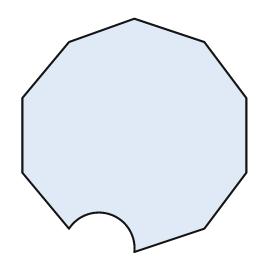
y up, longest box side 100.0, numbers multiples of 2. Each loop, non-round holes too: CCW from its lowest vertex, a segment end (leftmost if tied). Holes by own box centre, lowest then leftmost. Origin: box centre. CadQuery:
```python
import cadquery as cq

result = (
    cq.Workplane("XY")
    .moveTo(0.0, -50.0)
    .lineTo(30.0, -40.0)
    .lineTo(48.0, -16.0)
    .lineTo(48.0, 16.0)
    .lineTo(30.0, 40.0)
    .lineTo(0.0, 50.0)
    .lineTo(-28.0, 40.0)
    .lineTo(-48.0, 16.0)
    .lineTo(-48.0, -16.0)
    .lineTo(-28.0, -40.0)
    .threePointArc((-10.0, -34.0), (0.0, -50.0))
    .close()
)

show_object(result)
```